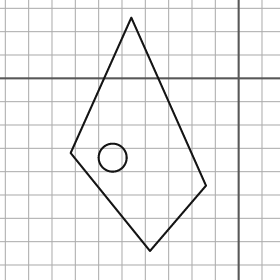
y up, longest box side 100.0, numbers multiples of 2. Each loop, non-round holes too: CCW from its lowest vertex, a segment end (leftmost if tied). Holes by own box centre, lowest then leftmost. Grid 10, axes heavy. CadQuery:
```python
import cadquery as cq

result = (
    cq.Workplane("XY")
    .moveTo(-38.0, -74.0)
    .lineTo(-14.0, -46.0)
    .lineTo(-46.0, 26.0)
    .lineTo(-72.0, -32.0)
    .close()
    .moveTo(-54.0, -34.0)
    .circle(6.0)
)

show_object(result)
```